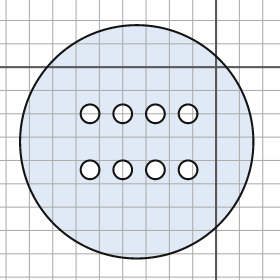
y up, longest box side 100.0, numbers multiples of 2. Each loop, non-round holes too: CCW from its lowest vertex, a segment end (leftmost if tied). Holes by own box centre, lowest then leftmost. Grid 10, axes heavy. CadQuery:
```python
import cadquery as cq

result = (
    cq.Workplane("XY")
    .moveTo(-34.0, -32.0)
    .circle(50.0)
    .moveTo(-54.0, -44.0)
    .circle(4.0)
    .moveTo(-40.0, -44.0)
    .circle(4.0)
    .moveTo(-26.0, -44.0)
    .circle(4.0)
    .moveTo(-12.0, -44.0)
    .circle(4.0)
    .moveTo(-54.0, -20.0)
    .circle(4.0)
    .moveTo(-40.0, -20.0)
    .circle(4.0)
    .moveTo(-26.0, -20.0)
    .circle(4.0)
    .moveTo(-12.0, -20.0)
    .circle(4.0)
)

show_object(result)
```